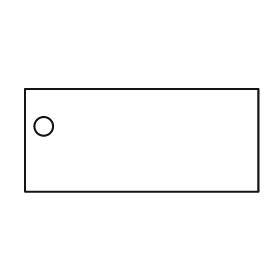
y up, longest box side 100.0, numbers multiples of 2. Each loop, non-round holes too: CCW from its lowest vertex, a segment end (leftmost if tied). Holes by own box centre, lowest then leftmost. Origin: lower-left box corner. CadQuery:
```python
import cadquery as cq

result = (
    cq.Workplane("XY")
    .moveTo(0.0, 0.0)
    .lineTo(100.0, 0.0)
    .lineTo(100.0, 44.0)
    .lineTo(0.0, 44.0)
    .close()
    .moveTo(8.0, 28.0)
    .circle(4.0)
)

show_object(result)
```